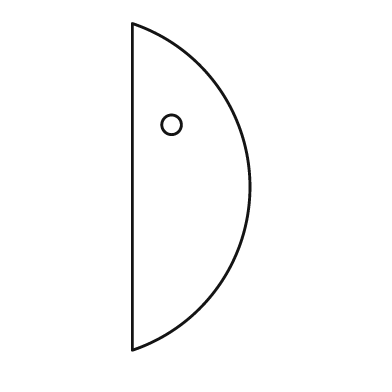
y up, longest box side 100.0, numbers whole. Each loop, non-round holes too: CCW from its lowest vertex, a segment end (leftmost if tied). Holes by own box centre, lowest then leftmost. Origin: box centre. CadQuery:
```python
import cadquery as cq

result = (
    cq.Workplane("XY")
    .moveTo(-18.0, -50.0)
    .threePointArc((18.0, 0.0), (-18.0, 50.0))
    .close()
    .moveTo(-6.0, 19.0)
    .circle(3.0)
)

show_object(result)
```